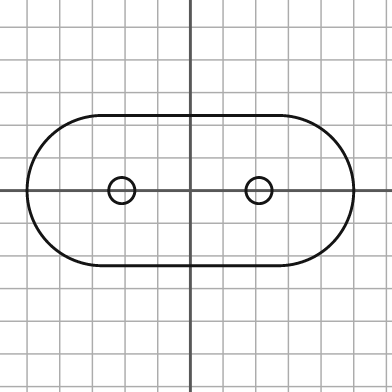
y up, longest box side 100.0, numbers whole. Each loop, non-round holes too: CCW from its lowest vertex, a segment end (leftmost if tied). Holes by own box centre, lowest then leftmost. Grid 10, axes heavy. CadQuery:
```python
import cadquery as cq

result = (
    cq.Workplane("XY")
    .moveTo(-27.0, -23.0)
    .lineTo(27.0, -23.0)
    .threePointArc((50.0, 0.0), (27.0, 23.0))
    .lineTo(-27.0, 23.0)
    .threePointArc((-50.0, 0.0), (-27.0, -23.0))
    .close()
    .moveTo(-21.0, 0.0)
    .circle(4.0)
    .moveTo(21.0, 0.0)
    .circle(4.0)
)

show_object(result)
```